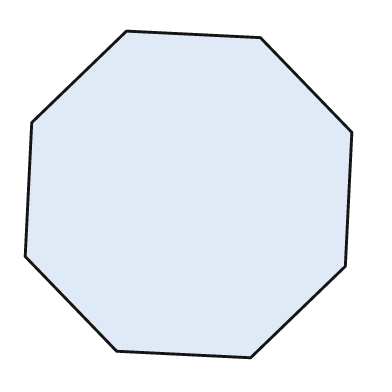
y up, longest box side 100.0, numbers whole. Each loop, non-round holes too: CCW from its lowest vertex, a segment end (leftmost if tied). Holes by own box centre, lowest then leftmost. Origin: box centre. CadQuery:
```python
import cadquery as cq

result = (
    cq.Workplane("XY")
    .moveTo(19.0, -50.0)
    .lineTo(48.0, -22.0)
    .lineTo(50.0, 19.0)
    .lineTo(22.0, 48.0)
    .lineTo(-19.0, 50.0)
    .lineTo(-48.0, 22.0)
    .lineTo(-50.0, -19.0)
    .lineTo(-22.0, -48.0)
    .close()
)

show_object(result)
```